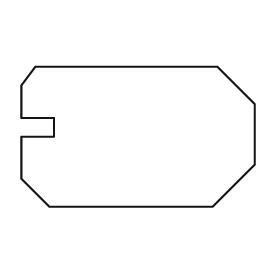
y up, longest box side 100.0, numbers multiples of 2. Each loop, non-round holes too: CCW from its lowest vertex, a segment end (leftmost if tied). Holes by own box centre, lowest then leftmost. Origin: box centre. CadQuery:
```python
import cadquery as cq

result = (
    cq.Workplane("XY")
    .moveTo(-38.0, -30.0)
    .lineTo(32.0, -30.0)
    .lineTo(50.0, -12.0)
    .lineTo(50.0, 14.0)
    .lineTo(34.0, 30.0)
    .lineTo(-44.0, 30.0)
    .lineTo(-50.0, 22.0)
    .lineTo(-50.0, 8.0)
    .lineTo(-36.0, 8.0)
    .lineTo(-36.0, 0.0)
    .lineTo(-50.0, 0.0)
    .lineTo(-50.0, -18.0)
    .close()
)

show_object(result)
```